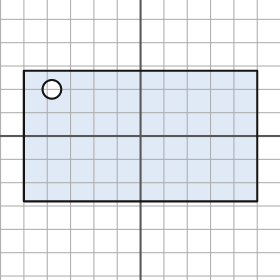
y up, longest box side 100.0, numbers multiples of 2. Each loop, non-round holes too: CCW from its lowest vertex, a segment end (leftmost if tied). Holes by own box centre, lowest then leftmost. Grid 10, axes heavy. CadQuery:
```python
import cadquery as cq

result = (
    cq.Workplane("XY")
    .moveTo(-50.0, -28.0)
    .lineTo(50.0, -28.0)
    .lineTo(50.0, 28.0)
    .lineTo(-50.0, 28.0)
    .close()
    .moveTo(-38.0, 20.0)
    .circle(4.0)
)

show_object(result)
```